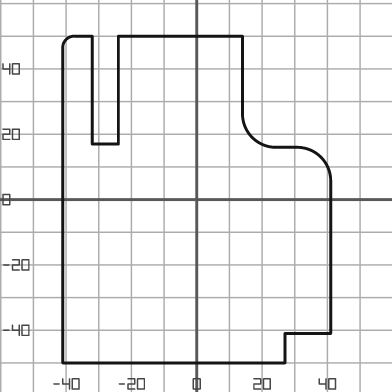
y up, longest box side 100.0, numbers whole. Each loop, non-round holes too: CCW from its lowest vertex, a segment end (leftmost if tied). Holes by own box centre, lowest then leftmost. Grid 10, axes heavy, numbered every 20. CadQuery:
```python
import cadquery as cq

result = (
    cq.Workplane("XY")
    .moveTo(-41.0, -50.0)
    .lineTo(27.0, -50.0)
    .lineTo(27.0, -41.0)
    .lineTo(41.0, -41.0)
    .lineTo(41.0, 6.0)
    .threePointArc((38.0, 13.0), (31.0, 16.0))
    .lineTo(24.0, 16.0)
    .threePointArc((17.0, 19.0), (14.0, 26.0))
    .lineTo(14.0, 50.0)
    .lineTo(-24.0, 50.0)
    .lineTo(-24.0, 17.0)
    .lineTo(-32.0, 17.0)
    .lineTo(-32.0, 50.0)
    .lineTo(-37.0, 50.0)
    .threePointArc((-40.0, 49.0), (-41.0, 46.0))
    .close()
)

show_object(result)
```